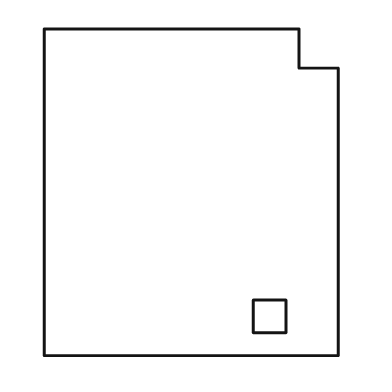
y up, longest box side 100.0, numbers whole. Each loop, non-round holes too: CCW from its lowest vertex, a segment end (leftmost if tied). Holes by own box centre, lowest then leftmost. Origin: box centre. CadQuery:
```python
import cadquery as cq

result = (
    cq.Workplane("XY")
    .moveTo(-45.0, -50.0)
    .lineTo(45.0, -50.0)
    .lineTo(45.0, 38.0)
    .lineTo(33.0, 38.0)
    .lineTo(33.0, 50.0)
    .lineTo(-45.0, 50.0)
    .close()
    .moveTo(19.0, -43.0)
    .lineTo(29.0, -43.0)
    .lineTo(29.0, -33.0)
    .lineTo(19.0, -33.0)
    .close()
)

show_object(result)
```